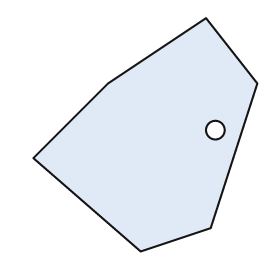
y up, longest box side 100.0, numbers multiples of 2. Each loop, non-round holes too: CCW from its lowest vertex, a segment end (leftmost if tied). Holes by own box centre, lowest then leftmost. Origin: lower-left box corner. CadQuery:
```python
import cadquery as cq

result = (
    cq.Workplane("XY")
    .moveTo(46.0, 0.0)
    .lineTo(76.0, 10.0)
    .lineTo(96.0, 72.0)
    .lineTo(74.0, 100.0)
    .lineTo(32.0, 72.0)
    .lineTo(0.0, 40.0)
    .close()
    .moveTo(78.0, 52.0)
    .circle(4.0)
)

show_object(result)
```